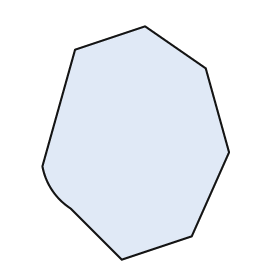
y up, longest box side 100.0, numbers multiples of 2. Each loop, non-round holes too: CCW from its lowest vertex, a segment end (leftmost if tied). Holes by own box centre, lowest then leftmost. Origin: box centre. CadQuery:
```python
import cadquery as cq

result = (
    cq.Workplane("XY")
    .moveTo(-6.0, -50.0)
    .lineTo(24.0, -40.0)
    .lineTo(40.0, -4.0)
    .lineTo(30.0, 32.0)
    .lineTo(4.0, 50.0)
    .lineTo(-26.0, 40.0)
    .lineTo(-40.0, -10.0)
    .threePointArc((-36.0, -20.0), (-28.0, -28.0))
    .close()
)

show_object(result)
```